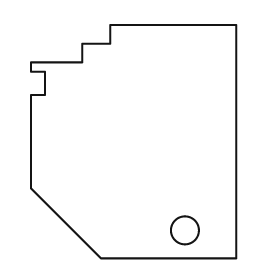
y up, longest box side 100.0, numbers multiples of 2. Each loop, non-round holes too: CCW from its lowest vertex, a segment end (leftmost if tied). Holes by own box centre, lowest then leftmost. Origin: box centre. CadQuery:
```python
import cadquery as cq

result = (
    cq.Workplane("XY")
    .moveTo(-14.0, -50.0)
    .lineTo(44.0, -50.0)
    .lineTo(44.0, 50.0)
    .lineTo(-10.0, 50.0)
    .lineTo(-10.0, 42.0)
    .lineTo(-22.0, 42.0)
    .lineTo(-22.0, 34.0)
    .lineTo(-44.0, 34.0)
    .lineTo(-44.0, 30.0)
    .lineTo(-38.0, 30.0)
    .lineTo(-38.0, 20.0)
    .lineTo(-44.0, 20.0)
    .lineTo(-44.0, -20.0)
    .close()
    .moveTo(22.0, -38.0)
    .circle(6.0)
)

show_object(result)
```